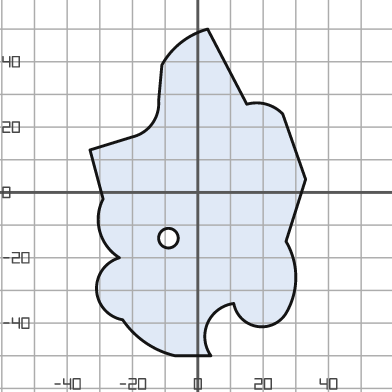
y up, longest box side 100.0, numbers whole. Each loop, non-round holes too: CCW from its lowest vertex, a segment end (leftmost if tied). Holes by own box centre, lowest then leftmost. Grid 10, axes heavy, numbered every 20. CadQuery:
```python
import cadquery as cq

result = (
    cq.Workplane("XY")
    .moveTo(-7.0, -50.0)
    .lineTo(4.0, -50.0)
    .threePointArc((3.0, -40.0), (11.0, -34.0))
    .threePointArc((18.0, -41.0), (27.0, -37.0))
    .threePointArc((30.0, -26.0), (27.0, -15.0))
    .lineTo(33.0, 4.0)
    .lineTo(26.0, 24.0)
    .threePointArc((21.0, 27.0), (15.0, 27.0))
    .lineTo(3.0, 50.0)
    .threePointArc((-5.0, 46.0), (-11.0, 39.0))
    .lineTo(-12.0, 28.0)
    .threePointArc((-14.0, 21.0), (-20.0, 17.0))
    .lineTo(-33.0, 13.0)
    .lineTo(-29.0, -2.0)
    .threePointArc((-30.0, -12.0), (-24.0, -20.0))
    .threePointArc((-31.0, -30.0), (-23.0, -39.0))
    .threePointArc((-16.0, -46.0), (-7.0, -50.0))
    .close()
    .moveTo(-9.0, -14.0)
    .circle(3.0)
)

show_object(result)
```